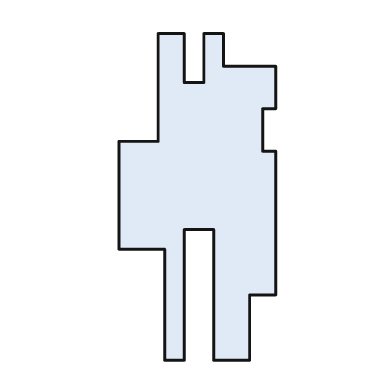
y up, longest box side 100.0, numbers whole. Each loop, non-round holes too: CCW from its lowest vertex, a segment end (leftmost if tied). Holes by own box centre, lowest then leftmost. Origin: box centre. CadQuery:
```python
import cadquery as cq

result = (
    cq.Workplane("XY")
    .moveTo(-10.0, -50.0)
    .lineTo(-4.0, -50.0)
    .lineTo(-4.0, -10.0)
    .lineTo(5.0, -10.0)
    .lineTo(5.0, -50.0)
    .lineTo(16.0, -50.0)
    .lineTo(16.0, -30.0)
    .lineTo(24.0, -30.0)
    .lineTo(24.0, 14.0)
    .lineTo(20.0, 14.0)
    .lineTo(20.0, 27.0)
    .lineTo(24.0, 27.0)
    .lineTo(24.0, 40.0)
    .lineTo(8.0, 40.0)
    .lineTo(8.0, 50.0)
    .lineTo(2.0, 50.0)
    .lineTo(2.0, 35.0)
    .lineTo(-4.0, 35.0)
    .lineTo(-4.0, 50.0)
    .lineTo(-12.0, 50.0)
    .lineTo(-12.0, 17.0)
    .lineTo(-24.0, 17.0)
    .lineTo(-24.0, -16.0)
    .lineTo(-10.0, -16.0)
    .close()
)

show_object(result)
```